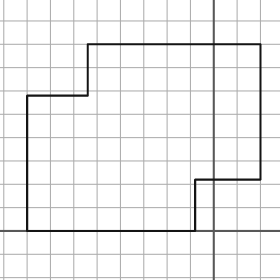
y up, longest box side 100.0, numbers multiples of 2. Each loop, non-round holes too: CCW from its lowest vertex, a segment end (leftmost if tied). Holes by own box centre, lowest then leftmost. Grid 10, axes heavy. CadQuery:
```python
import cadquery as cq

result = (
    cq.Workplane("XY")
    .moveTo(-80.0, 0.0)
    .lineTo(-8.0, 0.0)
    .lineTo(-8.0, 22.0)
    .lineTo(20.0, 22.0)
    .lineTo(20.0, 80.0)
    .lineTo(-54.0, 80.0)
    .lineTo(-54.0, 58.0)
    .lineTo(-80.0, 58.0)
    .close()
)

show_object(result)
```